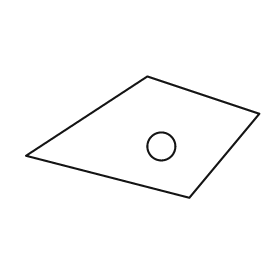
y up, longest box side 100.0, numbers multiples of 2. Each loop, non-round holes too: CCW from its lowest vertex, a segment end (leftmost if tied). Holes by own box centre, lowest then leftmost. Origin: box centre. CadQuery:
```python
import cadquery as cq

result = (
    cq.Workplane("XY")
    .moveTo(20.0, -26.0)
    .lineTo(50.0, 10.0)
    .lineTo(2.0, 26.0)
    .lineTo(-50.0, -8.0)
    .close()
    .moveTo(8.0, -4.0)
    .circle(6.0)
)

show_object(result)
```